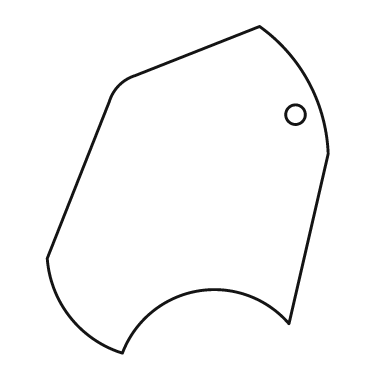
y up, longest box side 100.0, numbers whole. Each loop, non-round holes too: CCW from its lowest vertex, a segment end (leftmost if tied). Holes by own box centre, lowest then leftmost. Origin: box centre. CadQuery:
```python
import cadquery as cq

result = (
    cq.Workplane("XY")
    .moveTo(-20.0, -50.0)
    .threePointArc((3.0, -31.0), (31.0, -41.0))
    .lineTo(43.0, 11.0)
    .threePointArc((37.0, 33.0), (22.0, 50.0))
    .lineTo(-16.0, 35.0)
    .threePointArc((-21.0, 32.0), (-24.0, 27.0))
    .lineTo(-43.0, -21.0)
    .threePointArc((-36.0, -39.0), (-20.0, -50.0))
    .close()
    .moveTo(33.0, 23.0)
    .circle(3.0)
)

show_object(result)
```